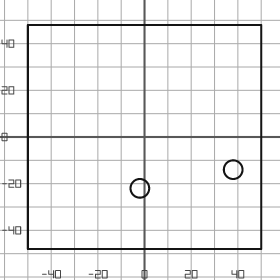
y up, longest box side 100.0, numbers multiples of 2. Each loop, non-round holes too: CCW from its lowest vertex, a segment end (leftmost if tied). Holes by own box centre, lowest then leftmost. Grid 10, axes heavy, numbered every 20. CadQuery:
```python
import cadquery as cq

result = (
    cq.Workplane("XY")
    .moveTo(-50.0, -48.0)
    .lineTo(50.0, -48.0)
    .lineTo(50.0, 48.0)
    .lineTo(-50.0, 48.0)
    .close()
    .moveTo(-2.0, -22.0)
    .circle(4.0)
    .moveTo(38.0, -14.0)
    .circle(4.0)
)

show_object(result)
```